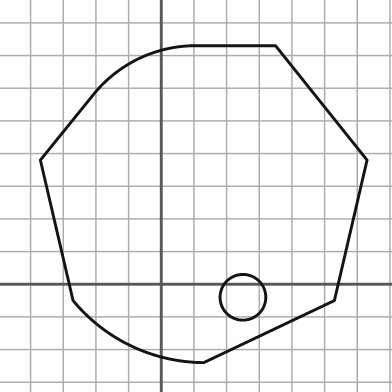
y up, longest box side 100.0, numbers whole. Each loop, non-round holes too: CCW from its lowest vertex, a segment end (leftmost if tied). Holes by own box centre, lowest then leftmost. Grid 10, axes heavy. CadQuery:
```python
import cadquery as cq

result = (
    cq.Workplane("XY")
    .moveTo(13.0, -24.0)
    .lineTo(53.0, -5.0)
    .lineTo(63.0, 38.0)
    .lineTo(35.0, 73.0)
    .lineTo(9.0, 73.0)
    .threePointArc((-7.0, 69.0), (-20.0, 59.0))
    .lineTo(-37.0, 38.0)
    .lineTo(-27.0, -5.0)
    .threePointArc((-9.0, -19.0), (13.0, -24.0))
    .close()
    .moveTo(25.0, -4.0)
    .circle(7.0)
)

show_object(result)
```